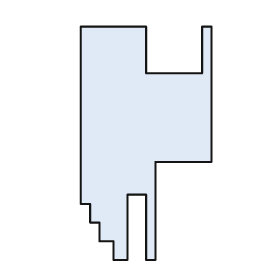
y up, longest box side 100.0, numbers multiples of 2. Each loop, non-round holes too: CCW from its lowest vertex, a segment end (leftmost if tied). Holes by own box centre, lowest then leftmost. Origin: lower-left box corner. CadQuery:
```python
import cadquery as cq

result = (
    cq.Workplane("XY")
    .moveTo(14.0, 0.0)
    .lineTo(20.0, 0.0)
    .lineTo(20.0, 28.0)
    .lineTo(28.0, 28.0)
    .lineTo(28.0, 0.0)
    .lineTo(32.0, 0.0)
    .lineTo(32.0, 42.0)
    .lineTo(56.0, 42.0)
    .lineTo(56.0, 100.0)
    .lineTo(52.0, 100.0)
    .lineTo(52.0, 80.0)
    .lineTo(28.0, 80.0)
    .lineTo(28.0, 100.0)
    .lineTo(0.0, 100.0)
    .lineTo(0.0, 24.0)
    .lineTo(4.0, 24.0)
    .lineTo(4.0, 16.0)
    .lineTo(8.0, 16.0)
    .lineTo(8.0, 8.0)
    .lineTo(14.0, 8.0)
    .close()
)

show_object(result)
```